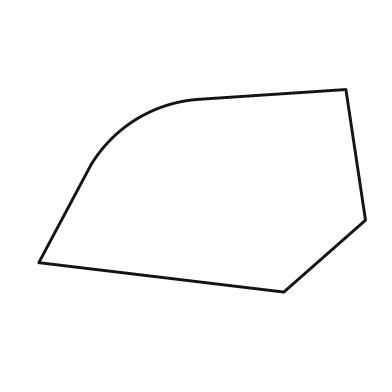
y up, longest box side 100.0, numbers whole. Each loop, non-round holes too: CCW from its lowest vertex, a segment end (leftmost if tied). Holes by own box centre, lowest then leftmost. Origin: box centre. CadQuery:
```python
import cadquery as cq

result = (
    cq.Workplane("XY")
    .moveTo(25.0, -31.0)
    .lineTo(50.0, -9.0)
    .lineTo(44.0, 31.0)
    .lineTo(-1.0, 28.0)
    .threePointArc((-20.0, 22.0), (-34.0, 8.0))
    .lineTo(-50.0, -22.0)
    .close()
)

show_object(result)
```